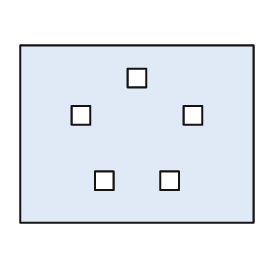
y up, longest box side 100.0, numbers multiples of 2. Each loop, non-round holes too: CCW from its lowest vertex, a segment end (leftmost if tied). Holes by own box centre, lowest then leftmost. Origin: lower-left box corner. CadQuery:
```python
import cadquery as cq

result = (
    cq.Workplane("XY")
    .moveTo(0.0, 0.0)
    .lineTo(100.0, 0.0)
    .lineTo(100.0, 76.0)
    .lineTo(0.0, 76.0)
    .close()
    .moveTo(32.0, 14.0)
    .lineTo(40.0, 14.0)
    .lineTo(40.0, 22.0)
    .lineTo(32.0, 22.0)
    .close()
    .moveTo(60.0, 14.0)
    .lineTo(68.0, 14.0)
    .lineTo(68.0, 22.0)
    .lineTo(60.0, 22.0)
    .close()
    .moveTo(22.0, 42.0)
    .lineTo(30.0, 42.0)
    .lineTo(30.0, 50.0)
    .lineTo(22.0, 50.0)
    .close()
    .moveTo(70.0, 42.0)
    .lineTo(78.0, 42.0)
    .lineTo(78.0, 50.0)
    .lineTo(70.0, 50.0)
    .close()
    .moveTo(46.0, 58.0)
    .lineTo(54.0, 58.0)
    .lineTo(54.0, 66.0)
    .lineTo(46.0, 66.0)
    .close()
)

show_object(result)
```